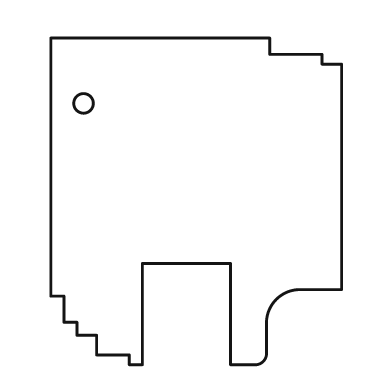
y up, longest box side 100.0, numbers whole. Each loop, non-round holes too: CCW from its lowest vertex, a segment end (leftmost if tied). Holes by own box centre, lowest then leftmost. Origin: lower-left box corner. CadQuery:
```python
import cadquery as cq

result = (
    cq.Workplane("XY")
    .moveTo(24.0, 0.0)
    .lineTo(28.0, 0.0)
    .lineTo(28.0, 31.0)
    .lineTo(55.0, 31.0)
    .lineTo(55.0, 0.0)
    .lineTo(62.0, 0.0)
    .threePointArc((65.0, 1.0), (66.0, 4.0))
    .lineTo(66.0, 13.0)
    .threePointArc((69.0, 20.0), (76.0, 23.0))
    .lineTo(89.0, 23.0)
    .lineTo(89.0, 92.0)
    .lineTo(83.0, 92.0)
    .lineTo(83.0, 95.0)
    .lineTo(67.0, 95.0)
    .lineTo(67.0, 100.0)
    .lineTo(0.0, 100.0)
    .lineTo(0.0, 21.0)
    .lineTo(4.0, 21.0)
    .lineTo(4.0, 13.0)
    .lineTo(8.0, 13.0)
    .lineTo(8.0, 9.0)
    .lineTo(14.0, 9.0)
    .lineTo(14.0, 3.0)
    .lineTo(24.0, 3.0)
    .close()
    .moveTo(10.0, 80.0)
    .circle(3.0)
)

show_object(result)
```